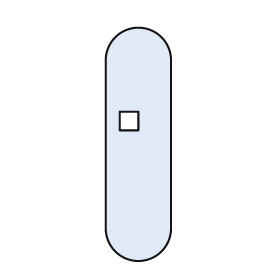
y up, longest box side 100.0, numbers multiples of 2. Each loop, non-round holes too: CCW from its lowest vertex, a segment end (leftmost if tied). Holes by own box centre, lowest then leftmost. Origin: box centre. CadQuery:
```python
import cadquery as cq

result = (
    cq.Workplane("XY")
    .moveTo(-14.0, -36.0)
    .threePointArc((0.0, -50.0), (14.0, -36.0))
    .lineTo(14.0, 36.0)
    .threePointArc((0.0, 50.0), (-14.0, 36.0))
    .close()
    .moveTo(-8.0, 6.0)
    .lineTo(0.0, 6.0)
    .lineTo(0.0, 14.0)
    .lineTo(-8.0, 14.0)
    .close()
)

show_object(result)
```